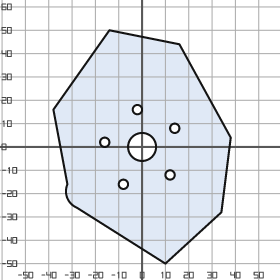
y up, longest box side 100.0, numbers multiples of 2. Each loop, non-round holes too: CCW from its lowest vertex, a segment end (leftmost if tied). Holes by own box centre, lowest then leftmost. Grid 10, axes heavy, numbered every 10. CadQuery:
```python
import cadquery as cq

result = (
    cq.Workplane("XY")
    .moveTo(10.0, -50.0)
    .lineTo(34.0, -28.0)
    .lineTo(38.0, 4.0)
    .lineTo(16.0, 44.0)
    .lineTo(-14.0, 50.0)
    .lineTo(-38.0, 16.0)
    .lineTo(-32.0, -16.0)
    .threePointArc((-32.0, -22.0), (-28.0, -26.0))
    .close()
    .moveTo(-8.0, -16.0)
    .circle(2.0)
    .moveTo(12.0, -12.0)
    .circle(2.0)
    .moveTo(0.0, 0.0)
    .circle(6.0)
    .moveTo(-16.0, 2.0)
    .circle(2.0)
    .moveTo(14.0, 8.0)
    .circle(2.0)
    .moveTo(-2.0, 16.0)
    .circle(2.0)
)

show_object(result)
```